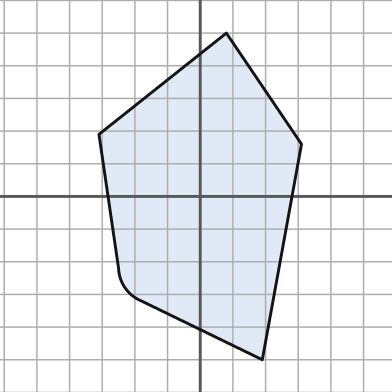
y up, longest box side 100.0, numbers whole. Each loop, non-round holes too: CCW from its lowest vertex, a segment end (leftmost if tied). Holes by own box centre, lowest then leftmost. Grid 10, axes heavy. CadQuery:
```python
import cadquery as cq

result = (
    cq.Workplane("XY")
    .moveTo(19.0, -50.0)
    .lineTo(31.0, 16.0)
    .lineTo(8.0, 50.0)
    .lineTo(-31.0, 19.0)
    .lineTo(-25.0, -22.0)
    .threePointArc((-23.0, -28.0), (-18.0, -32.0))
    .close()
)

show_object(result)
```